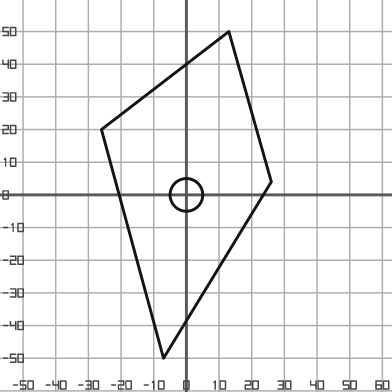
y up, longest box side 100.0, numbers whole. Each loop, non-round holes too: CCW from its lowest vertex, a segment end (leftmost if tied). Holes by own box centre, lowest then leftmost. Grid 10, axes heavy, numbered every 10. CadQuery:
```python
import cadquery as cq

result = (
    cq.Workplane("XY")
    .moveTo(-7.0, -50.0)
    .lineTo(26.0, 4.0)
    .lineTo(13.0, 50.0)
    .lineTo(-26.0, 20.0)
    .close()
    .moveTo(0.0, 0.0)
    .circle(5.0)
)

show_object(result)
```